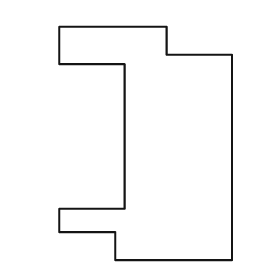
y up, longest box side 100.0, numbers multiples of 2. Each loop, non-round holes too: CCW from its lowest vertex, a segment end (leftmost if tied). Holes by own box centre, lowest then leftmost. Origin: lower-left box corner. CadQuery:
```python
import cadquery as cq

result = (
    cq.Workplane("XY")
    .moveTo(24.0, 0.0)
    .lineTo(74.0, 0.0)
    .lineTo(74.0, 88.0)
    .lineTo(46.0, 88.0)
    .lineTo(46.0, 100.0)
    .lineTo(0.0, 100.0)
    .lineTo(0.0, 84.0)
    .lineTo(28.0, 84.0)
    .lineTo(28.0, 22.0)
    .lineTo(0.0, 22.0)
    .lineTo(0.0, 12.0)
    .lineTo(24.0, 12.0)
    .close()
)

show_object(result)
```